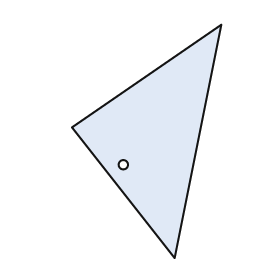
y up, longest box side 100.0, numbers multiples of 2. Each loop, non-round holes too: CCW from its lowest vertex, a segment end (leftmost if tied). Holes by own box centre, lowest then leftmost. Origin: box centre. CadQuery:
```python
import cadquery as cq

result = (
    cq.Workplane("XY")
    .moveTo(12.0, -50.0)
    .lineTo(32.0, 50.0)
    .lineTo(-32.0, 6.0)
    .close()
    .moveTo(-10.0, -10.0)
    .circle(2.0)
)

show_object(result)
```